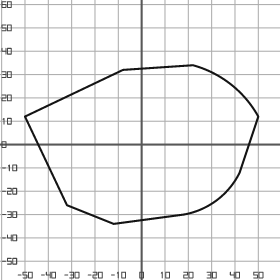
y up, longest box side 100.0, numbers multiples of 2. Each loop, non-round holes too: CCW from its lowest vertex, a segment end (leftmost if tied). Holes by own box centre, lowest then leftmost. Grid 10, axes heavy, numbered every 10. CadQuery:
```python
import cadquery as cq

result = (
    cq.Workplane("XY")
    .moveTo(-12.0, -34.0)
    .lineTo(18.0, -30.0)
    .threePointArc((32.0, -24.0), (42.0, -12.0))
    .lineTo(50.0, 12.0)
    .threePointArc((38.0, 26.0), (22.0, 34.0))
    .lineTo(-8.0, 32.0)
    .lineTo(-50.0, 12.0)
    .lineTo(-32.0, -26.0)
    .close()
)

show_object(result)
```